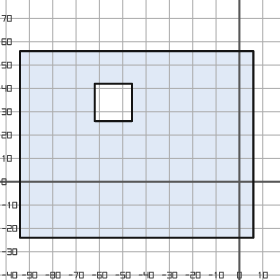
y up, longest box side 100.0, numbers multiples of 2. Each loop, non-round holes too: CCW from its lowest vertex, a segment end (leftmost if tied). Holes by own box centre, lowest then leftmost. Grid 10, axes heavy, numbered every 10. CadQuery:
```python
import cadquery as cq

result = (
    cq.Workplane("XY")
    .moveTo(-94.0, -24.0)
    .lineTo(6.0, -24.0)
    .lineTo(6.0, 56.0)
    .lineTo(-94.0, 56.0)
    .close()
    .moveTo(-62.0, 26.0)
    .lineTo(-46.0, 26.0)
    .lineTo(-46.0, 42.0)
    .lineTo(-62.0, 42.0)
    .close()
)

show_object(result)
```